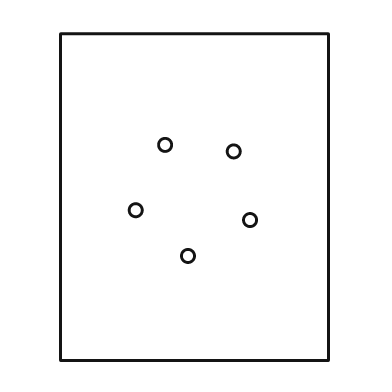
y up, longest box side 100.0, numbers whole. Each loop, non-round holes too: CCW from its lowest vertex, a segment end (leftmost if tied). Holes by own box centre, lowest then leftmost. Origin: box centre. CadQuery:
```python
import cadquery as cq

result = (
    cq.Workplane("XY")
    .moveTo(-41.0, -50.0)
    .lineTo(41.0, -50.0)
    .lineTo(41.0, 50.0)
    .lineTo(-41.0, 50.0)
    .close()
    .moveTo(-2.0, -18.0)
    .circle(2.0)
    .moveTo(17.0, -7.0)
    .circle(2.0)
    .moveTo(-18.0, -4.0)
    .circle(2.0)
    .moveTo(12.0, 14.0)
    .circle(2.0)
    .moveTo(-9.0, 16.0)
    .circle(2.0)
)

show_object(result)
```